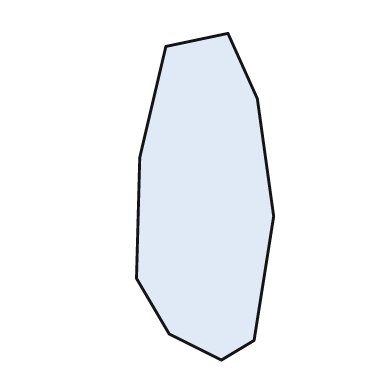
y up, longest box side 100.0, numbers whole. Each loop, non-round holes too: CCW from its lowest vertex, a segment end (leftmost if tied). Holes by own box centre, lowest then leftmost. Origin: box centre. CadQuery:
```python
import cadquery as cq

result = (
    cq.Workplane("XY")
    .moveTo(5.0, -50.0)
    .lineTo(15.0, -44.0)
    .lineTo(21.0, -6.0)
    .lineTo(16.0, 30.0)
    .lineTo(7.0, 50.0)
    .lineTo(-12.0, 46.0)
    .lineTo(-20.0, 12.0)
    .lineTo(-21.0, -25.0)
    .lineTo(-11.0, -42.0)
    .close()
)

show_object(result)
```